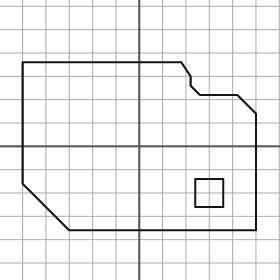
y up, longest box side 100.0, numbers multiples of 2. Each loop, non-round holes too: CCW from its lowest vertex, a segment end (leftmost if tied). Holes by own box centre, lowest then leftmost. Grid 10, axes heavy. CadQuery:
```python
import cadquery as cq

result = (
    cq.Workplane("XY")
    .moveTo(-30.0, -36.0)
    .lineTo(50.0, -36.0)
    .lineTo(50.0, 14.0)
    .lineTo(42.0, 22.0)
    .lineTo(26.0, 22.0)
    .lineTo(22.0, 26.0)
    .lineTo(22.0, 30.0)
    .lineTo(18.0, 36.0)
    .lineTo(-50.0, 36.0)
    .lineTo(-50.0, -16.0)
    .close()
    .moveTo(24.0, -26.0)
    .lineTo(36.0, -26.0)
    .lineTo(36.0, -14.0)
    .lineTo(24.0, -14.0)
    .close()
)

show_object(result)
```